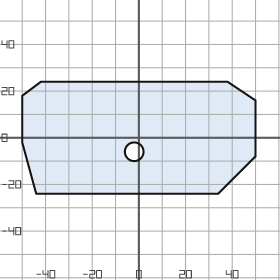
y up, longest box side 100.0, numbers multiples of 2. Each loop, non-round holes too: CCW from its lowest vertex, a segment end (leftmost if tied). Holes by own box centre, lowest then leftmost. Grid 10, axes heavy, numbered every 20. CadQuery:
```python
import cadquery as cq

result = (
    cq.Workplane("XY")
    .moveTo(-44.0, -24.0)
    .lineTo(34.0, -24.0)
    .lineTo(50.0, -8.0)
    .lineTo(50.0, 16.0)
    .lineTo(38.0, 24.0)
    .lineTo(-42.0, 24.0)
    .lineTo(-50.0, 18.0)
    .lineTo(-50.0, -2.0)
    .close()
    .moveTo(-2.0, -6.0)
    .circle(4.0)
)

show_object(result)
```